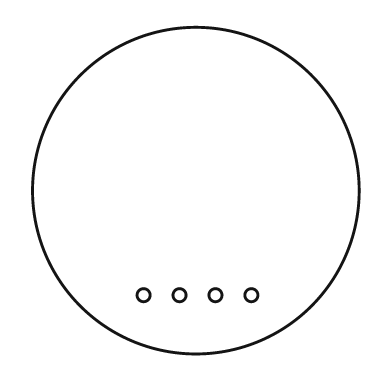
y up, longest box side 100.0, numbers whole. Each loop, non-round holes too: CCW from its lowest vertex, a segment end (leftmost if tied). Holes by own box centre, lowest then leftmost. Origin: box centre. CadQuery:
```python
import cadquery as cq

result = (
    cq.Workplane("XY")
    .moveTo(0.0, 0.0)
    .circle(50.0)
    .moveTo(-16.0, -32.0)
    .circle(2.0)
    .moveTo(-5.0, -32.0)
    .circle(2.0)
    .moveTo(6.0, -32.0)
    .circle(2.0)
    .moveTo(17.0, -32.0)
    .circle(2.0)
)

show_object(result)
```